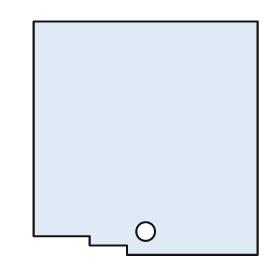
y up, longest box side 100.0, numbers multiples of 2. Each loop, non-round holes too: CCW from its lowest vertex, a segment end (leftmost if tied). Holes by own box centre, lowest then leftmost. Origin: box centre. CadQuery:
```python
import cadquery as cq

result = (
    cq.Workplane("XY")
    .moveTo(-8.0, -50.0)
    .lineTo(48.0, -50.0)
    .lineTo(48.0, 50.0)
    .lineTo(-48.0, 50.0)
    .lineTo(-48.0, -42.0)
    .lineTo(-24.0, -42.0)
    .lineTo(-24.0, -46.0)
    .lineTo(-8.0, -46.0)
    .close()
    .moveTo(0.0, -40.0)
    .circle(4.0)
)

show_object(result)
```